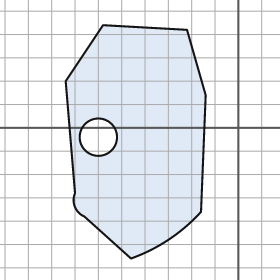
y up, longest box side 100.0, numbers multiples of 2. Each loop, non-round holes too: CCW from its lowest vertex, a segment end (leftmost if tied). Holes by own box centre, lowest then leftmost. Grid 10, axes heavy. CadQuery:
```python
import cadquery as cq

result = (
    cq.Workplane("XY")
    .moveTo(-46.0, -56.0)
    .threePointArc((-30.0, -48.0), (-16.0, -36.0))
    .lineTo(-14.0, 14.0)
    .lineTo(-22.0, 42.0)
    .lineTo(-58.0, 44.0)
    .lineTo(-74.0, 20.0)
    .lineTo(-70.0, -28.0)
    .threePointArc((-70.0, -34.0), (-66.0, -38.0))
    .close()
    .moveTo(-60.0, -4.0)
    .circle(8.0)
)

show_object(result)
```